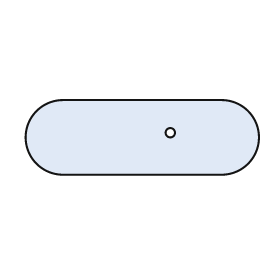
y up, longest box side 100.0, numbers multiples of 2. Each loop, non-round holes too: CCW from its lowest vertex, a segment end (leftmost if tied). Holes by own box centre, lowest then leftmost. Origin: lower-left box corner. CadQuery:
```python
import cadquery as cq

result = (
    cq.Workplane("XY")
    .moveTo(16.0, 0.0)
    .lineTo(84.0, 0.0)
    .threePointArc((100.0, 16.0), (84.0, 32.0))
    .lineTo(16.0, 32.0)
    .threePointArc((0.0, 16.0), (16.0, 0.0))
    .close()
    .moveTo(62.0, 18.0)
    .circle(2.0)
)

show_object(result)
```